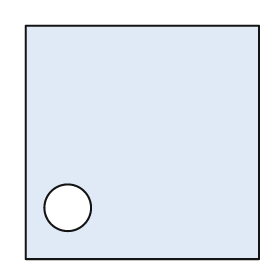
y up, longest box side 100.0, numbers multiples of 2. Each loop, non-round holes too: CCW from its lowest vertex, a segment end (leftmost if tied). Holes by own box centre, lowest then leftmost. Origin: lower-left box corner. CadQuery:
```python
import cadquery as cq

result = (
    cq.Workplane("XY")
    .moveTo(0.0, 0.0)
    .lineTo(100.0, 0.0)
    .lineTo(100.0, 100.0)
    .lineTo(0.0, 100.0)
    .close()
    .moveTo(18.0, 22.0)
    .circle(10.0)
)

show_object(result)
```